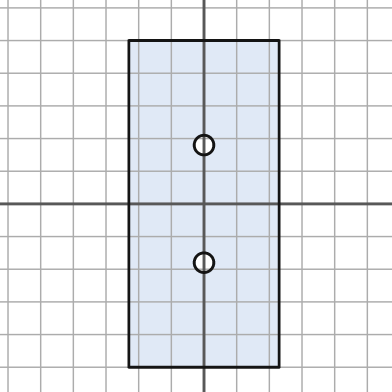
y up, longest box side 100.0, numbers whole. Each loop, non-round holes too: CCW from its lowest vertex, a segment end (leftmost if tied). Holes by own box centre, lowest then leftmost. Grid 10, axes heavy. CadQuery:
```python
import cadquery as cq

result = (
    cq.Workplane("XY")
    .moveTo(-23.0, -50.0)
    .lineTo(23.0, -50.0)
    .lineTo(23.0, 50.0)
    .lineTo(-23.0, 50.0)
    .close()
    .moveTo(0.0, -18.0)
    .circle(3.0)
    .moveTo(0.0, 18.0)
    .circle(3.0)
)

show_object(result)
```